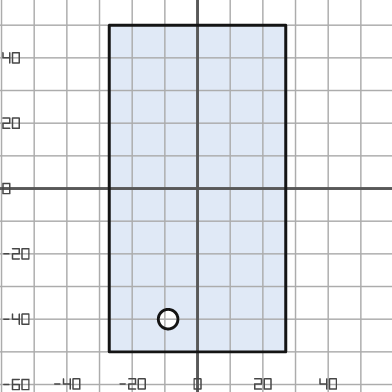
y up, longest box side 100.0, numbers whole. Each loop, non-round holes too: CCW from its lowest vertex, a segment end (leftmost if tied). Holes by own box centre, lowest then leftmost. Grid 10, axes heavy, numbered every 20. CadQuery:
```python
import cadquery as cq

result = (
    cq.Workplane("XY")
    .moveTo(-27.0, -50.0)
    .lineTo(27.0, -50.0)
    .lineTo(27.0, 50.0)
    .lineTo(-27.0, 50.0)
    .close()
    .moveTo(-9.0, -40.0)
    .circle(3.0)
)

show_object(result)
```